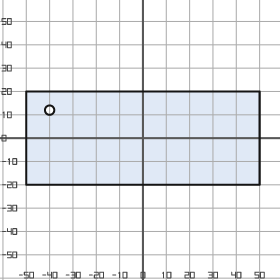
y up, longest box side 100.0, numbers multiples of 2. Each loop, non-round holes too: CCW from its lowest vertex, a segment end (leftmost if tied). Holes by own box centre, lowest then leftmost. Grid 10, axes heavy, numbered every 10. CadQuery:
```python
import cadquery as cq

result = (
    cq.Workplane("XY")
    .moveTo(-50.0, -20.0)
    .lineTo(50.0, -20.0)
    .lineTo(50.0, 20.0)
    .lineTo(-50.0, 20.0)
    .close()
    .moveTo(-40.0, 12.0)
    .circle(2.0)
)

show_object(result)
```